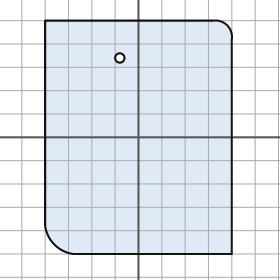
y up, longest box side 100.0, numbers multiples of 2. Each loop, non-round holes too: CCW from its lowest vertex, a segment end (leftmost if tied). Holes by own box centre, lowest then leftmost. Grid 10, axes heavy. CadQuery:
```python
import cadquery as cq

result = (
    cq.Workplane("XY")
    .moveTo(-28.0, -50.0)
    .lineTo(40.0, -50.0)
    .lineTo(40.0, 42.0)
    .threePointArc((38.0, 48.0), (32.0, 50.0))
    .lineTo(-40.0, 50.0)
    .lineTo(-40.0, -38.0)
    .threePointArc((-36.0, -46.0), (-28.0, -50.0))
    .close()
    .moveTo(-8.0, 34.0)
    .circle(2.0)
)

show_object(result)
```